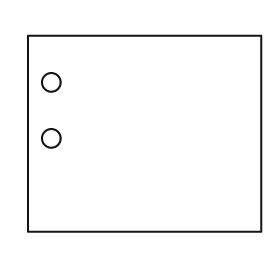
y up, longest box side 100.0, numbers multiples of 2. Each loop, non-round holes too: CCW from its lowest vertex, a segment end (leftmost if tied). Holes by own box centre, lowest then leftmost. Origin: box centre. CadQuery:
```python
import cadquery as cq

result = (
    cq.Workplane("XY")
    .moveTo(-50.0, -42.0)
    .lineTo(50.0, -42.0)
    .lineTo(50.0, 42.0)
    .lineTo(-50.0, 42.0)
    .close()
    .moveTo(-40.0, -2.0)
    .circle(4.0)
    .moveTo(-40.0, 22.0)
    .circle(4.0)
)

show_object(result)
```